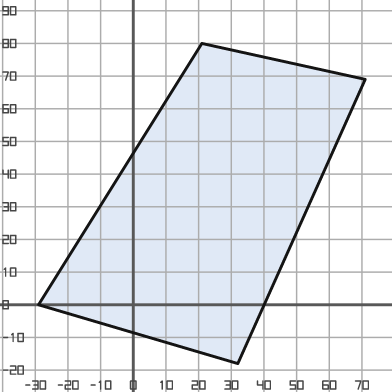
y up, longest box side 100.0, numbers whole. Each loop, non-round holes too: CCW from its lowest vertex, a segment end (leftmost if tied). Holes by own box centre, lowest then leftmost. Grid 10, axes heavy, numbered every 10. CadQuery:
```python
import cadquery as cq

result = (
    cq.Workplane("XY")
    .moveTo(32.0, -18.0)
    .lineTo(71.0, 69.0)
    .lineTo(21.0, 80.0)
    .lineTo(-29.0, 0.0)
    .close()
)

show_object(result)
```